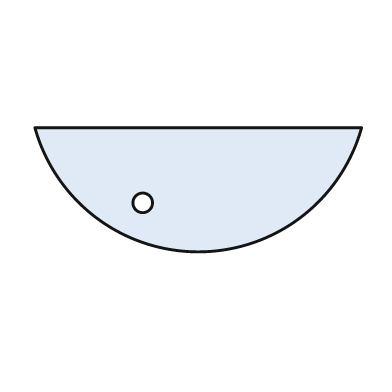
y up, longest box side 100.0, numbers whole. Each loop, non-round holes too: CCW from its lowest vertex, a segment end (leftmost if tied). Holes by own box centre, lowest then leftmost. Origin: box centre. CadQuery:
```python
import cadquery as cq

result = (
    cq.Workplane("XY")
    .moveTo(-50.0, 19.0)
    .threePointArc((0.0, -19.0), (50.0, 19.0))
    .close()
    .moveTo(-17.0, -4.0)
    .circle(3.0)
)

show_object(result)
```